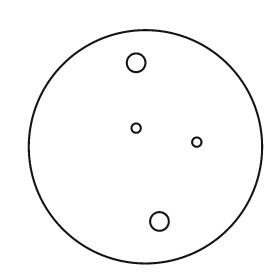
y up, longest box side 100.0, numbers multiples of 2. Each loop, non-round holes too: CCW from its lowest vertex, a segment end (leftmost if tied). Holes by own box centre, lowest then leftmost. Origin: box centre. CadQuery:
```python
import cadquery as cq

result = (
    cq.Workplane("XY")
    .moveTo(0.0, 0.0)
    .circle(50.0)
    .moveTo(6.0, -32.0)
    .circle(4.0)
    .moveTo(22.0, 2.0)
    .circle(2.0)
    .moveTo(-4.0, 8.0)
    .circle(2.0)
    .moveTo(-4.0, 36.0)
    .circle(4.0)
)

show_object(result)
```